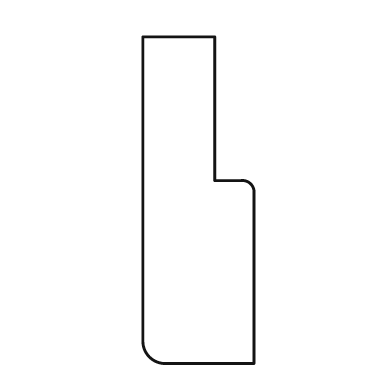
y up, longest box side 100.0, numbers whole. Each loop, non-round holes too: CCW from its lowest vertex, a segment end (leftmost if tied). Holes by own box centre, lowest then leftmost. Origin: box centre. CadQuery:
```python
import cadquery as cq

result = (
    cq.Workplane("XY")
    .moveTo(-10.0, -50.0)
    .lineTo(17.0, -50.0)
    .lineTo(17.0, 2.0)
    .threePointArc((16.0, 5.0), (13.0, 6.0))
    .lineTo(5.0, 6.0)
    .lineTo(5.0, 50.0)
    .lineTo(-17.0, 50.0)
    .lineTo(-17.0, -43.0)
    .threePointArc((-15.0, -48.0), (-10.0, -50.0))
    .close()
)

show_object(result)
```